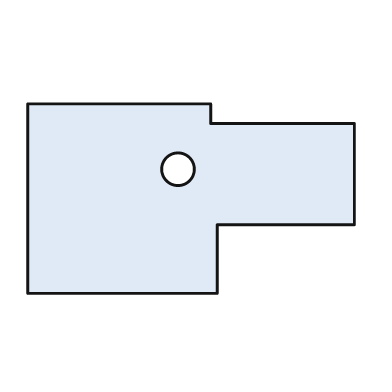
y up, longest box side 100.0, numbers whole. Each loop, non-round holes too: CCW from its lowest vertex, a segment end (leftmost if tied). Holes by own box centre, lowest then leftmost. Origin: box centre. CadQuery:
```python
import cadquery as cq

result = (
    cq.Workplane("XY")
    .moveTo(-50.0, -29.0)
    .lineTo(8.0, -29.0)
    .lineTo(8.0, -8.0)
    .lineTo(50.0, -8.0)
    .lineTo(50.0, 23.0)
    .lineTo(6.0, 23.0)
    .lineTo(6.0, 29.0)
    .lineTo(-50.0, 29.0)
    .close()
    .moveTo(-4.0, 9.0)
    .circle(5.0)
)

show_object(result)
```